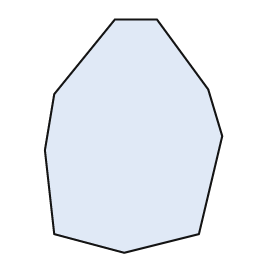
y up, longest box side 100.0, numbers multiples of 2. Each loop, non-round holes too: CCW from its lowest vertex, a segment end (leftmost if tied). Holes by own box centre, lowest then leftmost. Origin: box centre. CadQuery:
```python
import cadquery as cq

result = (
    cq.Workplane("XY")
    .moveTo(-4.0, -50.0)
    .lineTo(28.0, -42.0)
    .lineTo(38.0, 0.0)
    .lineTo(32.0, 20.0)
    .lineTo(10.0, 50.0)
    .lineTo(-8.0, 50.0)
    .lineTo(-34.0, 18.0)
    .lineTo(-38.0, -6.0)
    .lineTo(-34.0, -42.0)
    .close()
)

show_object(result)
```